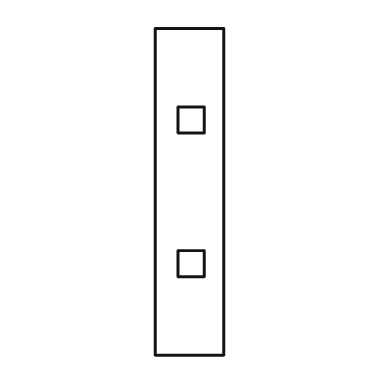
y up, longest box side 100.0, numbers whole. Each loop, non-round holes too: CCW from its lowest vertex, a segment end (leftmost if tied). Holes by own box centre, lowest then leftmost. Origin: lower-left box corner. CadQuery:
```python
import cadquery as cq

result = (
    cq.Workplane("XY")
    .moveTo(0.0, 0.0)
    .lineTo(21.0, 0.0)
    .lineTo(21.0, 100.0)
    .lineTo(0.0, 100.0)
    .close()
    .moveTo(7.0, 24.0)
    .lineTo(15.0, 24.0)
    .lineTo(15.0, 32.0)
    .lineTo(7.0, 32.0)
    .close()
    .moveTo(7.0, 68.0)
    .lineTo(15.0, 68.0)
    .lineTo(15.0, 76.0)
    .lineTo(7.0, 76.0)
    .close()
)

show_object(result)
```